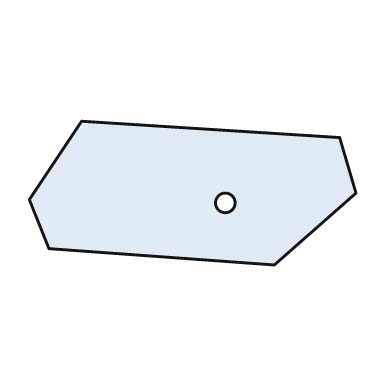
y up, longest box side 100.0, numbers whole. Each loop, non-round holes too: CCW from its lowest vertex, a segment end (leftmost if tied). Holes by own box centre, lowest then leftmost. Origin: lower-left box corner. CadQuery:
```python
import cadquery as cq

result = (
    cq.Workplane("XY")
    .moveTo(75.0, 0.0)
    .lineTo(100.0, 22.0)
    .lineTo(95.0, 39.0)
    .lineTo(16.0, 44.0)
    .lineTo(0.0, 20.0)
    .lineTo(6.0, 5.0)
    .close()
    .moveTo(60.0, 19.0)
    .circle(3.0)
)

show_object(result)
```